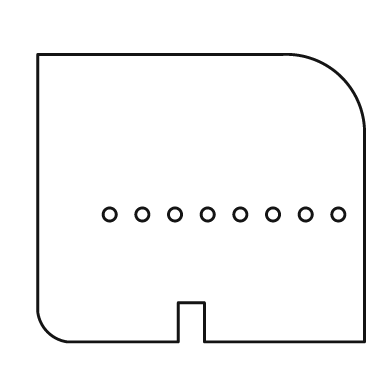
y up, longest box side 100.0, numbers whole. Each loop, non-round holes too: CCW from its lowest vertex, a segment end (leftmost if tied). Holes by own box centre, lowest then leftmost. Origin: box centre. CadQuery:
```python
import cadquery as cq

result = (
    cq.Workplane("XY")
    .moveTo(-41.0, -44.0)
    .lineTo(-7.0, -44.0)
    .lineTo(-7.0, -32.0)
    .lineTo(1.0, -32.0)
    .lineTo(1.0, -44.0)
    .lineTo(50.0, -44.0)
    .lineTo(50.0, 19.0)
    .threePointArc((43.0, 37.0), (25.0, 44.0))
    .lineTo(-50.0, 44.0)
    .lineTo(-50.0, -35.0)
    .threePointArc((-47.0, -41.0), (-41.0, -44.0))
    .close()
    .moveTo(-28.0, -5.0)
    .circle(2.0)
    .moveTo(-18.0, -5.0)
    .circle(2.0)
    .moveTo(-8.0, -5.0)
    .circle(2.0)
    .moveTo(2.0, -5.0)
    .circle(2.0)
    .moveTo(12.0, -5.0)
    .circle(2.0)
    .moveTo(22.0, -5.0)
    .circle(2.0)
    .moveTo(32.0, -5.0)
    .circle(2.0)
    .moveTo(42.0, -5.0)
    .circle(2.0)
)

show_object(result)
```